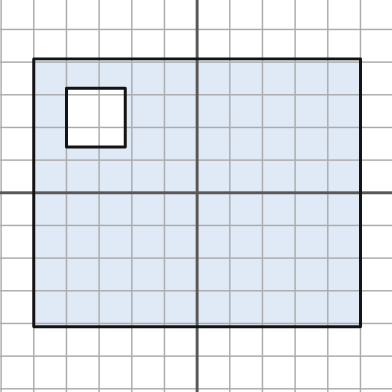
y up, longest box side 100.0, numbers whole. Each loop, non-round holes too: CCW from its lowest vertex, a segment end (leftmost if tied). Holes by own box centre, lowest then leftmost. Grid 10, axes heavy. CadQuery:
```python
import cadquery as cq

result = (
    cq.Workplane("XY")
    .moveTo(-50.0, -41.0)
    .lineTo(50.0, -41.0)
    .lineTo(50.0, 41.0)
    .lineTo(-50.0, 41.0)
    .close()
    .moveTo(-40.0, 14.0)
    .lineTo(-22.0, 14.0)
    .lineTo(-22.0, 32.0)
    .lineTo(-40.0, 32.0)
    .close()
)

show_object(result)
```